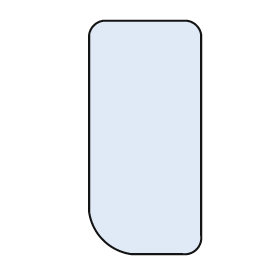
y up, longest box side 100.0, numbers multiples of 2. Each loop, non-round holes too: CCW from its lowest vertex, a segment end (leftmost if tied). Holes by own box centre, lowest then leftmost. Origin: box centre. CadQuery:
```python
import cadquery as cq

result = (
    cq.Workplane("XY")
    .moveTo(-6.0, -50.0)
    .lineTo(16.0, -50.0)
    .threePointArc((22.0, -48.0), (24.0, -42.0))
    .lineTo(24.0, 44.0)
    .threePointArc((22.0, 48.0), (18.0, 50.0))
    .lineTo(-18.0, 50.0)
    .threePointArc((-22.0, 48.0), (-24.0, 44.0))
    .lineTo(-24.0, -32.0)
    .threePointArc((-18.0, -44.0), (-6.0, -50.0))
    .close()
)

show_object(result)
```